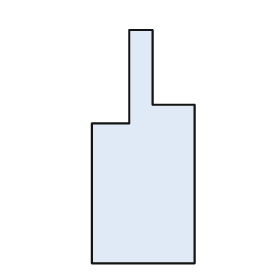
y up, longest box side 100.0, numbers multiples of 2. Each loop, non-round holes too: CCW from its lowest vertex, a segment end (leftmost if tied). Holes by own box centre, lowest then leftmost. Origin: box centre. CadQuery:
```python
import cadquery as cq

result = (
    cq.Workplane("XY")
    .moveTo(-22.0, -50.0)
    .lineTo(22.0, -50.0)
    .lineTo(22.0, 18.0)
    .lineTo(4.0, 18.0)
    .lineTo(4.0, 50.0)
    .lineTo(-6.0, 50.0)
    .lineTo(-6.0, 10.0)
    .lineTo(-22.0, 10.0)
    .close()
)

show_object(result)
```